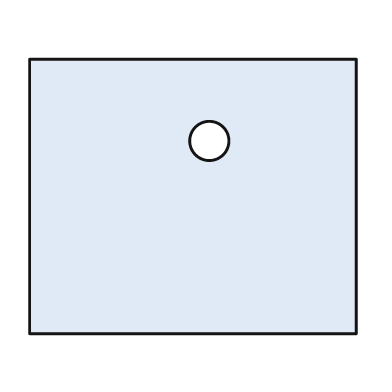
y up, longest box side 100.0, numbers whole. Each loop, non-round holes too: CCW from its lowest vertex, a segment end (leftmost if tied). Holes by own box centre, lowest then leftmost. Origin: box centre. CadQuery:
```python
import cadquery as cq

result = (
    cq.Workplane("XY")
    .moveTo(-50.0, -42.0)
    .lineTo(50.0, -42.0)
    .lineTo(50.0, 42.0)
    .lineTo(-50.0, 42.0)
    .close()
    .moveTo(5.0, 17.0)
    .circle(6.0)
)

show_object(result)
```